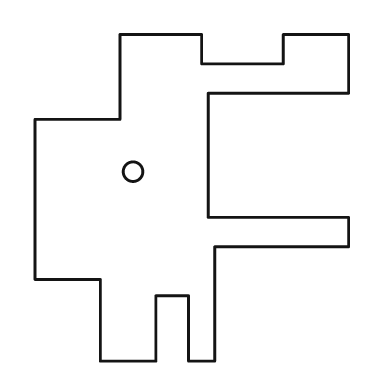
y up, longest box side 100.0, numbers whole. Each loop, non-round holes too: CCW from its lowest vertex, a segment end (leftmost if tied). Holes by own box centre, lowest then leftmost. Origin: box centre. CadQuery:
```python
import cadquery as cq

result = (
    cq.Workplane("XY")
    .moveTo(-28.0, -50.0)
    .lineTo(-11.0, -50.0)
    .lineTo(-11.0, -30.0)
    .lineTo(-1.0, -30.0)
    .lineTo(-1.0, -50.0)
    .lineTo(7.0, -50.0)
    .lineTo(7.0, -15.0)
    .lineTo(48.0, -15.0)
    .lineTo(48.0, -6.0)
    .lineTo(5.0, -6.0)
    .lineTo(5.0, 32.0)
    .lineTo(48.0, 32.0)
    .lineTo(48.0, 50.0)
    .lineTo(28.0, 50.0)
    .lineTo(28.0, 41.0)
    .lineTo(3.0, 41.0)
    .lineTo(3.0, 50.0)
    .lineTo(-22.0, 50.0)
    .lineTo(-22.0, 24.0)
    .lineTo(-48.0, 24.0)
    .lineTo(-48.0, -25.0)
    .lineTo(-28.0, -25.0)
    .close()
    .moveTo(-18.0, 8.0)
    .circle(3.0)
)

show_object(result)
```